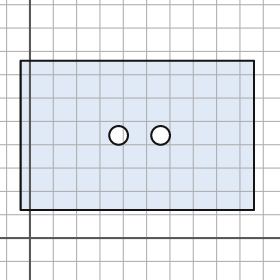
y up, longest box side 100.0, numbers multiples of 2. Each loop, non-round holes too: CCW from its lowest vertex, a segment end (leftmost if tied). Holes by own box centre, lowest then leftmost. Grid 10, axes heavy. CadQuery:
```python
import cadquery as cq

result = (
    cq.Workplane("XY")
    .moveTo(-4.0, 12.0)
    .lineTo(96.0, 12.0)
    .lineTo(96.0, 76.0)
    .lineTo(-4.0, 76.0)
    .close()
    .moveTo(38.0, 44.0)
    .circle(4.0)
    .moveTo(56.0, 44.0)
    .circle(4.0)
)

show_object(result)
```